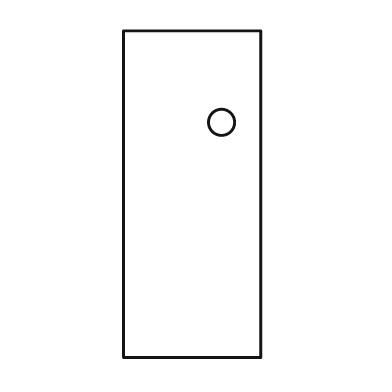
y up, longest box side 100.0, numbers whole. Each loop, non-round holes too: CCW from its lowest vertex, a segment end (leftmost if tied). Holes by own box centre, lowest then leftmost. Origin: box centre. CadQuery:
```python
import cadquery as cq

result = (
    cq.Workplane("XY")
    .moveTo(-21.0, -50.0)
    .lineTo(21.0, -50.0)
    .lineTo(21.0, 50.0)
    .lineTo(-21.0, 50.0)
    .close()
    .moveTo(9.0, 22.0)
    .circle(4.0)
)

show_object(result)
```